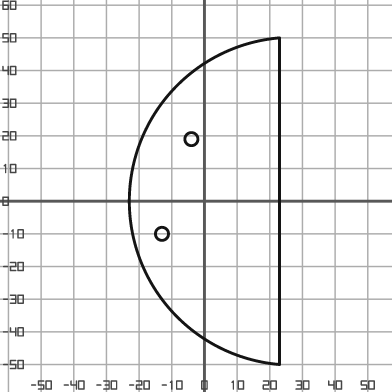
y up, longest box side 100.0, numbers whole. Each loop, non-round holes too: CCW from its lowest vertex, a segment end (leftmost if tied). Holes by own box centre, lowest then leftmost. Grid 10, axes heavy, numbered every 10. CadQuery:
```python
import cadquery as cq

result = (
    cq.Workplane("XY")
    .moveTo(23.0, -50.0)
    .lineTo(23.0, 50.0)
    .threePointArc((-23.0, 0.0), (23.0, -50.0))
    .close()
    .moveTo(-13.0, -10.0)
    .circle(2.0)
    .moveTo(-4.0, 19.0)
    .circle(2.0)
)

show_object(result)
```